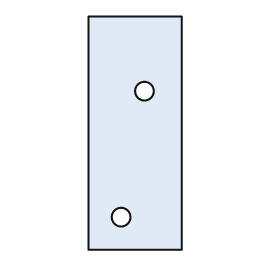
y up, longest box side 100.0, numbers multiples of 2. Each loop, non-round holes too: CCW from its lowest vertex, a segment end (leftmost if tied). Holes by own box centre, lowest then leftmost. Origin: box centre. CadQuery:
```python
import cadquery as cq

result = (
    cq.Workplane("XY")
    .moveTo(-20.0, -50.0)
    .lineTo(20.0, -50.0)
    .lineTo(20.0, 50.0)
    .lineTo(-20.0, 50.0)
    .close()
    .moveTo(-6.0, -36.0)
    .circle(4.0)
    .moveTo(4.0, 18.0)
    .circle(4.0)
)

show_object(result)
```